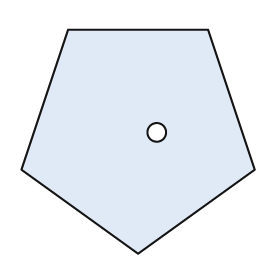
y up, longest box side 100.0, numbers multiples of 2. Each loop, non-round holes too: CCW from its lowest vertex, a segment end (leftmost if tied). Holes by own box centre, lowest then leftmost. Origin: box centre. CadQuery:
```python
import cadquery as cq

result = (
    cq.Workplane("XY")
    .moveTo(0.0, -48.0)
    .lineTo(50.0, -12.0)
    .lineTo(30.0, 48.0)
    .lineTo(-30.0, 48.0)
    .lineTo(-50.0, -12.0)
    .close()
    .moveTo(8.0, 4.0)
    .circle(4.0)
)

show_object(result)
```